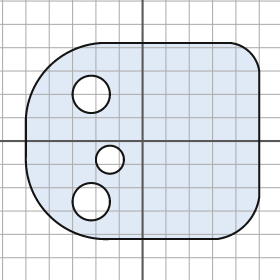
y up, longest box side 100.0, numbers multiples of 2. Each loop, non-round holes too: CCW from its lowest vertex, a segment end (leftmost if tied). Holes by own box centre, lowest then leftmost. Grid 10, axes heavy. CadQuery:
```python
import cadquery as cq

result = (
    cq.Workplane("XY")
    .moveTo(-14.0, -42.0)
    .lineTo(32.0, -42.0)
    .threePointArc((44.0, -36.0), (50.0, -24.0))
    .lineTo(50.0, 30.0)
    .threePointArc((46.0, 38.0), (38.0, 42.0))
    .lineTo(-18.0, 42.0)
    .threePointArc((-40.0, 32.0), (-50.0, 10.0))
    .lineTo(-50.0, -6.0)
    .threePointArc((-40.0, -32.0), (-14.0, -42.0))
    .close()
    .moveTo(-22.0, -26.0)
    .circle(8.0)
    .moveTo(-14.0, -8.0)
    .circle(6.0)
    .moveTo(-22.0, 20.0)
    .circle(8.0)
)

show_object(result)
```